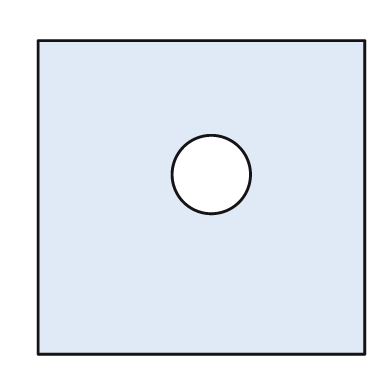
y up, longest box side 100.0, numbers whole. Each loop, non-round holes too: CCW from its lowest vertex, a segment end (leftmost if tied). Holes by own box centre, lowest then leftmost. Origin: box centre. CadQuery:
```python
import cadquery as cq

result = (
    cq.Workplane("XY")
    .moveTo(-50.0, -48.0)
    .lineTo(50.0, -48.0)
    .lineTo(50.0, 48.0)
    .lineTo(-50.0, 48.0)
    .close()
    .moveTo(3.0, 7.0)
    .circle(12.0)
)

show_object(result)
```